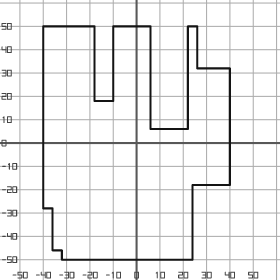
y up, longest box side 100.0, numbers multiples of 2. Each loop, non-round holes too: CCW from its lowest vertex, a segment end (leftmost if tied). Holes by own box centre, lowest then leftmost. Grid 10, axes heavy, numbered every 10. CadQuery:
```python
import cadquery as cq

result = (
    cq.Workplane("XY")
    .moveTo(-32.0, -50.0)
    .lineTo(24.0, -50.0)
    .lineTo(24.0, -18.0)
    .lineTo(40.0, -18.0)
    .lineTo(40.0, 32.0)
    .lineTo(26.0, 32.0)
    .lineTo(26.0, 50.0)
    .lineTo(22.0, 50.0)
    .lineTo(22.0, 6.0)
    .lineTo(6.0, 6.0)
    .lineTo(6.0, 50.0)
    .lineTo(-10.0, 50.0)
    .lineTo(-10.0, 18.0)
    .lineTo(-18.0, 18.0)
    .lineTo(-18.0, 50.0)
    .lineTo(-40.0, 50.0)
    .lineTo(-40.0, -28.0)
    .lineTo(-36.0, -28.0)
    .lineTo(-36.0, -46.0)
    .lineTo(-32.0, -46.0)
    .close()
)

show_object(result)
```